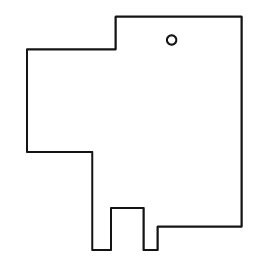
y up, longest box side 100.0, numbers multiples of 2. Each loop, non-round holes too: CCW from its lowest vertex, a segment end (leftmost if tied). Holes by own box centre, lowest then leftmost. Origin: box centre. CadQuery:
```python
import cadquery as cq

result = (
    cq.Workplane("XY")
    .moveTo(-18.0, -50.0)
    .lineTo(-10.0, -50.0)
    .lineTo(-10.0, -32.0)
    .lineTo(4.0, -32.0)
    .lineTo(4.0, -50.0)
    .lineTo(10.0, -50.0)
    .lineTo(10.0, -40.0)
    .lineTo(46.0, -40.0)
    .lineTo(46.0, 50.0)
    .lineTo(-8.0, 50.0)
    .lineTo(-8.0, 36.0)
    .lineTo(-46.0, 36.0)
    .lineTo(-46.0, -8.0)
    .lineTo(-18.0, -8.0)
    .close()
    .moveTo(16.0, 40.0)
    .circle(2.0)
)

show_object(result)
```